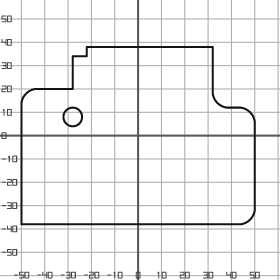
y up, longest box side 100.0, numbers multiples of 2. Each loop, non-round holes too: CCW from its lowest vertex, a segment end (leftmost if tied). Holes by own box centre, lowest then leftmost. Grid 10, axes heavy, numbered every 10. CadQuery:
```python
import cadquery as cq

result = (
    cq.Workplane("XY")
    .moveTo(-50.0, -38.0)
    .lineTo(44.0, -38.0)
    .threePointArc((48.0, -36.0), (50.0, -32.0))
    .lineTo(50.0, 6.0)
    .threePointArc((48.0, 10.0), (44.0, 12.0))
    .lineTo(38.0, 12.0)
    .threePointArc((34.0, 14.0), (32.0, 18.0))
    .lineTo(32.0, 38.0)
    .lineTo(-22.0, 38.0)
    .lineTo(-22.0, 34.0)
    .lineTo(-28.0, 34.0)
    .lineTo(-28.0, 20.0)
    .lineTo(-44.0, 20.0)
    .threePointArc((-48.0, 18.0), (-50.0, 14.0))
    .close()
    .moveTo(-28.0, 8.0)
    .circle(4.0)
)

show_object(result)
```